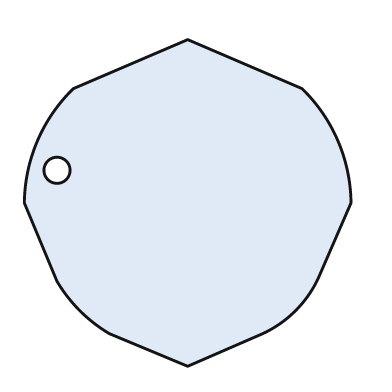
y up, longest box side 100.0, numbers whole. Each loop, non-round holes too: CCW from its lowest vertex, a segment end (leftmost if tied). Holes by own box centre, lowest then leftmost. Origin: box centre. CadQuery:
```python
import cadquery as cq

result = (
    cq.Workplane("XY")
    .moveTo(0.0, -50.0)
    .lineTo(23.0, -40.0)
    .threePointArc((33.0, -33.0), (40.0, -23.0))
    .lineTo(50.0, 0.0)
    .threePointArc((46.0, 19.0), (35.0, 35.0))
    .lineTo(0.0, 50.0)
    .lineTo(-35.0, 35.0)
    .threePointArc((-46.0, 19.0), (-50.0, 0.0))
    .lineTo(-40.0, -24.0)
    .threePointArc((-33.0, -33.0), (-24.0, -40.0))
    .close()
    .moveTo(-40.0, 10.0)
    .circle(4.0)
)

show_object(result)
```